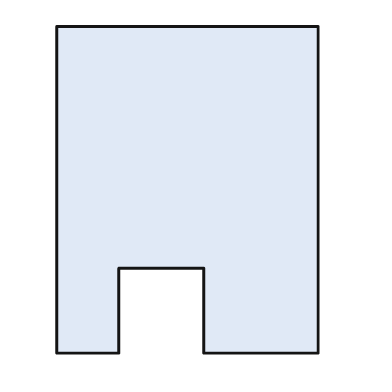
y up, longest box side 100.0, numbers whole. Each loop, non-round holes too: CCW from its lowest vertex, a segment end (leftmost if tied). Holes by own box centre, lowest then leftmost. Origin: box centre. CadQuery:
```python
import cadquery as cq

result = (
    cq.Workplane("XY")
    .moveTo(-40.0, -50.0)
    .lineTo(-21.0, -50.0)
    .lineTo(-21.0, -24.0)
    .lineTo(5.0, -24.0)
    .lineTo(5.0, -50.0)
    .lineTo(40.0, -50.0)
    .lineTo(40.0, 50.0)
    .lineTo(-40.0, 50.0)
    .close()
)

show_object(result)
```